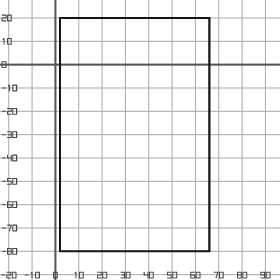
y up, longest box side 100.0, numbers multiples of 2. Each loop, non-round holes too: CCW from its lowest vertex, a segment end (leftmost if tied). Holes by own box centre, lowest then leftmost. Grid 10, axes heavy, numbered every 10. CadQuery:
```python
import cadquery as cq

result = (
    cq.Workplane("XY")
    .moveTo(2.0, -80.0)
    .lineTo(66.0, -80.0)
    .lineTo(66.0, 20.0)
    .lineTo(2.0, 20.0)
    .close()
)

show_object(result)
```